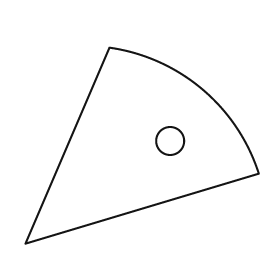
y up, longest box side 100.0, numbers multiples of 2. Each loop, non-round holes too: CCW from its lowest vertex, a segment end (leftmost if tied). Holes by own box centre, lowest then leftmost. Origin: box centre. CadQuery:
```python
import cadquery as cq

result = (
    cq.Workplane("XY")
    .moveTo(-50.0, -42.0)
    .lineTo(50.0, -12.0)
    .threePointArc((26.0, 24.0), (-14.0, 42.0))
    .close()
    .moveTo(12.0, 2.0)
    .circle(6.0)
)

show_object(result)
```